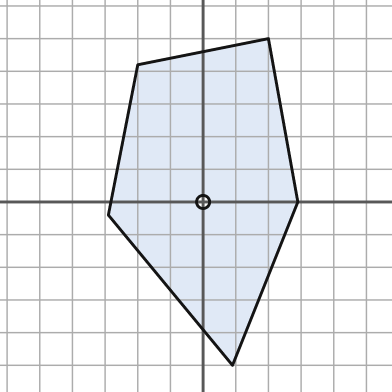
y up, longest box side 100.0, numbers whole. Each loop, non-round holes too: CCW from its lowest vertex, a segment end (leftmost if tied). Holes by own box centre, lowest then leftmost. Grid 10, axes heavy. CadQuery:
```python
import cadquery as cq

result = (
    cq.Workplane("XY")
    .moveTo(9.0, -50.0)
    .lineTo(29.0, 0.0)
    .lineTo(20.0, 50.0)
    .lineTo(-20.0, 42.0)
    .lineTo(-29.0, -4.0)
    .close()
    .moveTo(0.0, 0.0)
    .circle(2.0)
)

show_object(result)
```